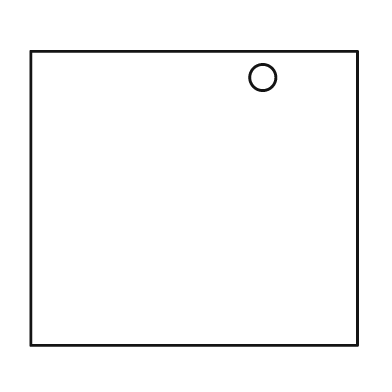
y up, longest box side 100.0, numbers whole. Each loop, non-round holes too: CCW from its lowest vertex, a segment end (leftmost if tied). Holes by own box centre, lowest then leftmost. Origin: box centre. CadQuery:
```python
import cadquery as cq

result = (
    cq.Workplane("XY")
    .moveTo(-50.0, -45.0)
    .lineTo(50.0, -45.0)
    .lineTo(50.0, 45.0)
    .lineTo(-50.0, 45.0)
    .close()
    .moveTo(21.0, 37.0)
    .circle(4.0)
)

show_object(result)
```